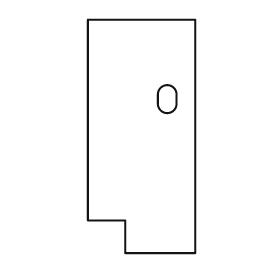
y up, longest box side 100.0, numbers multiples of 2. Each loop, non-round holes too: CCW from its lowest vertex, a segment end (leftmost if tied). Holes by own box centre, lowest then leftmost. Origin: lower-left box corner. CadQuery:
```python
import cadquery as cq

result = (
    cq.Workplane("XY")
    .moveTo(16.0, 0.0)
    .lineTo(46.0, 0.0)
    .lineTo(46.0, 100.0)
    .lineTo(0.0, 100.0)
    .lineTo(0.0, 14.0)
    .lineTo(16.0, 14.0)
    .close()
    .moveTo(30.0, 64.0)
    .threePointArc((34.0, 60.0), (38.0, 64.0))
    .lineTo(38.0, 68.0)
    .threePointArc((34.0, 72.0), (30.0, 68.0))
    .close()
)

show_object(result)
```